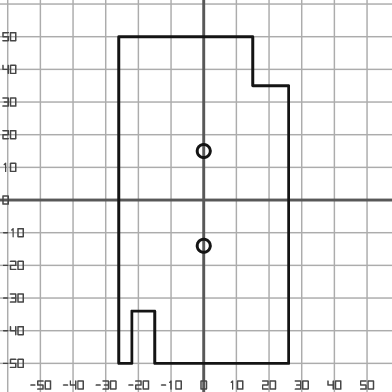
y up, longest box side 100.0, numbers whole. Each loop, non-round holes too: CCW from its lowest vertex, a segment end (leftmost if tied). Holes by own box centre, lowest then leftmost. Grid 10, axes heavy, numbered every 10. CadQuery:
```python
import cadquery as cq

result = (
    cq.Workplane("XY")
    .moveTo(-26.0, -50.0)
    .lineTo(-22.0, -50.0)
    .lineTo(-22.0, -34.0)
    .lineTo(-15.0, -34.0)
    .lineTo(-15.0, -50.0)
    .lineTo(26.0, -50.0)
    .lineTo(26.0, 35.0)
    .lineTo(15.0, 35.0)
    .lineTo(15.0, 50.0)
    .lineTo(-26.0, 50.0)
    .close()
    .moveTo(0.0, -14.0)
    .circle(2.0)
    .moveTo(0.0, 15.0)
    .circle(2.0)
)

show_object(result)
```